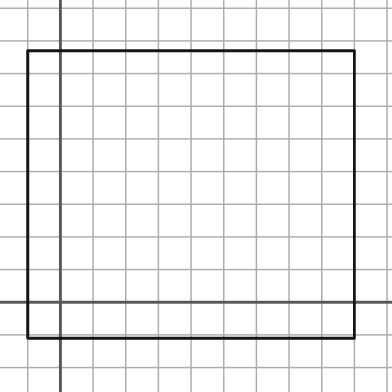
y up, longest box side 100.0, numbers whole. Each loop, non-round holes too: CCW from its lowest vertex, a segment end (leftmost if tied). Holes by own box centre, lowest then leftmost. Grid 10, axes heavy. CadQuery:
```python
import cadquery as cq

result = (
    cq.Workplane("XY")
    .moveTo(-10.0, -11.0)
    .lineTo(90.0, -11.0)
    .lineTo(90.0, 77.0)
    .lineTo(-10.0, 77.0)
    .close()
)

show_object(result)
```